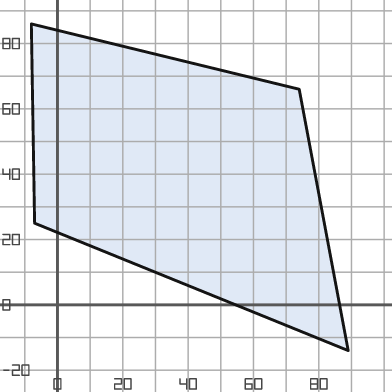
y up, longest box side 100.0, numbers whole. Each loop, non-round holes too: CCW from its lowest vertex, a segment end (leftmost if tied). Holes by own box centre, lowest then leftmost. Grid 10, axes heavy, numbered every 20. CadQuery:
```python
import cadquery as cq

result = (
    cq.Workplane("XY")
    .moveTo(89.0, -14.0)
    .lineTo(74.0, 66.0)
    .lineTo(-8.0, 86.0)
    .lineTo(-7.0, 25.0)
    .close()
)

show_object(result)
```